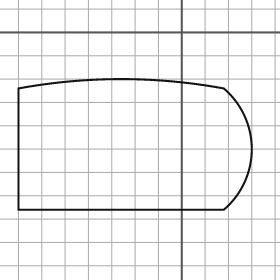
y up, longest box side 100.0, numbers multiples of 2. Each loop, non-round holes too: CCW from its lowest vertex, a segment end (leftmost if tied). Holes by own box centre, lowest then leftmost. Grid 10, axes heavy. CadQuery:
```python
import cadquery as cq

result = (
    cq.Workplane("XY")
    .moveTo(-70.0, -76.0)
    .lineTo(18.0, -76.0)
    .threePointArc((30.0, -50.0), (18.0, -24.0))
    .threePointArc((-26.0, -20.0), (-70.0, -24.0))
    .close()
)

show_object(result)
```